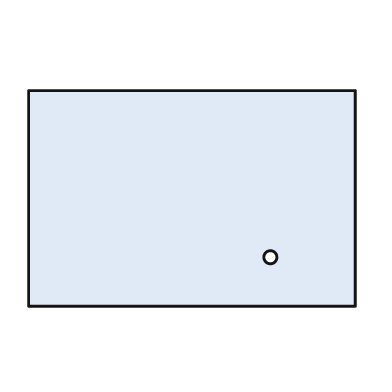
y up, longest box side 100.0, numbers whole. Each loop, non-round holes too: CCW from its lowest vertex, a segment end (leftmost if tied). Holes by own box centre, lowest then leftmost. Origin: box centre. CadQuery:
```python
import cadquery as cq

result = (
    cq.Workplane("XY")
    .moveTo(-50.0, -33.0)
    .lineTo(50.0, -33.0)
    .lineTo(50.0, 33.0)
    .lineTo(-50.0, 33.0)
    .close()
    .moveTo(24.0, -18.0)
    .circle(2.0)
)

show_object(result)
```